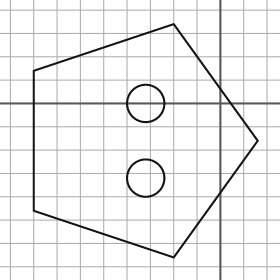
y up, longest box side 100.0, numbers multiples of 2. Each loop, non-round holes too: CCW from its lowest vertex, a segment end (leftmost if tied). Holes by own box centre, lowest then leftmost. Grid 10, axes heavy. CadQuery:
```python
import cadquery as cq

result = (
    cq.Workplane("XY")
    .moveTo(-20.0, -66.0)
    .lineTo(16.0, -16.0)
    .lineTo(-20.0, 34.0)
    .lineTo(-80.0, 14.0)
    .lineTo(-80.0, -46.0)
    .close()
    .moveTo(-32.0, -32.0)
    .circle(8.0)
    .moveTo(-32.0, 0.0)
    .circle(8.0)
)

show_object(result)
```